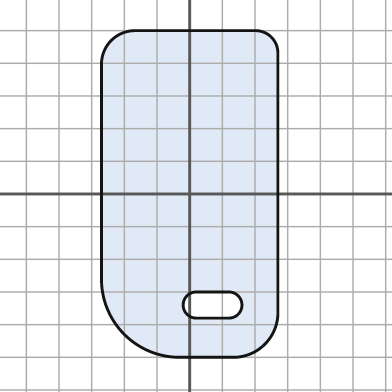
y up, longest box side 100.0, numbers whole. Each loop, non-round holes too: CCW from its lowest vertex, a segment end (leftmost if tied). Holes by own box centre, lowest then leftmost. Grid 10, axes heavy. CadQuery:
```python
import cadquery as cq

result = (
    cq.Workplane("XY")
    .moveTo(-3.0, -50.0)
    .lineTo(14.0, -50.0)
    .threePointArc((23.0, -46.0), (27.0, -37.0))
    .lineTo(27.0, 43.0)
    .threePointArc((25.0, 48.0), (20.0, 50.0))
    .lineTo(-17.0, 50.0)
    .threePointArc((-24.0, 47.0), (-27.0, 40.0))
    .lineTo(-27.0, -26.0)
    .threePointArc((-20.0, -43.0), (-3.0, -50.0))
    .close()
    .moveTo(2.0, -38.0)
    .lineTo(12.0, -38.0)
    .threePointArc((16.0, -34.0), (12.0, -30.0))
    .lineTo(2.0, -30.0)
    .threePointArc((-2.0, -34.0), (2.0, -38.0))
    .close()
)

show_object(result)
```